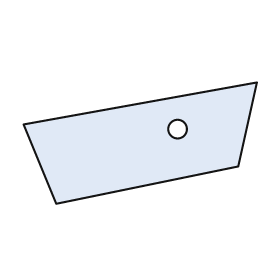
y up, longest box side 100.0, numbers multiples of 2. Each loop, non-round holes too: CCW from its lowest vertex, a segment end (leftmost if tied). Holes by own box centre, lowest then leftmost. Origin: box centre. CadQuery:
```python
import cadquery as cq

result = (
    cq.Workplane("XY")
    .moveTo(-36.0, -26.0)
    .lineTo(42.0, -10.0)
    .lineTo(50.0, 26.0)
    .lineTo(-50.0, 8.0)
    .close()
    .moveTo(16.0, 6.0)
    .circle(4.0)
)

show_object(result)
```